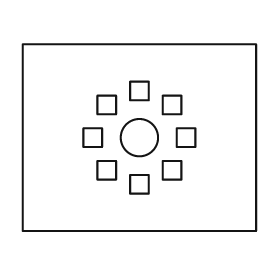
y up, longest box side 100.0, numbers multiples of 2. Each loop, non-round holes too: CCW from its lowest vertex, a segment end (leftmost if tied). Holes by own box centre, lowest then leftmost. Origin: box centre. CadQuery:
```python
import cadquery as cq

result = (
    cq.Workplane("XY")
    .moveTo(-50.0, -40.0)
    .lineTo(50.0, -40.0)
    .lineTo(50.0, 40.0)
    .lineTo(-50.0, 40.0)
    .close()
    .moveTo(-4.0, -24.0)
    .lineTo(4.0, -24.0)
    .lineTo(4.0, -16.0)
    .lineTo(-4.0, -16.0)
    .close()
    .moveTo(-18.0, -18.0)
    .lineTo(-10.0, -18.0)
    .lineTo(-10.0, -10.0)
    .lineTo(-18.0, -10.0)
    .close()
    .moveTo(10.0, -18.0)
    .lineTo(18.0, -18.0)
    .lineTo(18.0, -10.0)
    .lineTo(10.0, -10.0)
    .close()
    .moveTo(-24.0, -4.0)
    .lineTo(-16.0, -4.0)
    .lineTo(-16.0, 4.0)
    .lineTo(-24.0, 4.0)
    .close()
    .moveTo(0.0, 0.0)
    .circle(8.0)
    .moveTo(16.0, -4.0)
    .lineTo(24.0, -4.0)
    .lineTo(24.0, 4.0)
    .lineTo(16.0, 4.0)
    .close()
    .moveTo(-18.0, 10.0)
    .lineTo(-10.0, 10.0)
    .lineTo(-10.0, 18.0)
    .lineTo(-18.0, 18.0)
    .close()
    .moveTo(10.0, 10.0)
    .lineTo(18.0, 10.0)
    .lineTo(18.0, 18.0)
    .lineTo(10.0, 18.0)
    .close()
    .moveTo(-4.0, 16.0)
    .lineTo(4.0, 16.0)
    .lineTo(4.0, 24.0)
    .lineTo(-4.0, 24.0)
    .close()
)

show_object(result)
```